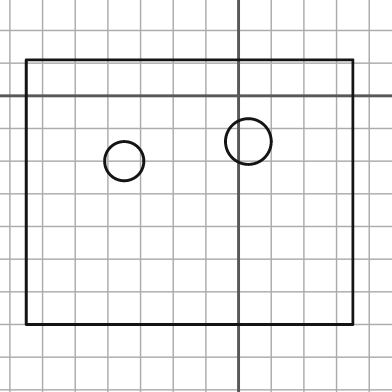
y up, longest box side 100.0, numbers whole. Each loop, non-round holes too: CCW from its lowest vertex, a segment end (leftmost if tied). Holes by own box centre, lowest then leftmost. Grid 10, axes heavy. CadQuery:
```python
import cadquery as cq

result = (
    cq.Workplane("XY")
    .moveTo(-65.0, -70.0)
    .lineTo(35.0, -70.0)
    .lineTo(35.0, 11.0)
    .lineTo(-65.0, 11.0)
    .close()
    .moveTo(-35.0, -20.0)
    .circle(6.0)
    .moveTo(3.0, -14.0)
    .circle(7.0)
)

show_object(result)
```